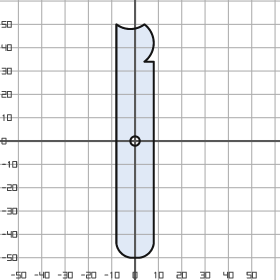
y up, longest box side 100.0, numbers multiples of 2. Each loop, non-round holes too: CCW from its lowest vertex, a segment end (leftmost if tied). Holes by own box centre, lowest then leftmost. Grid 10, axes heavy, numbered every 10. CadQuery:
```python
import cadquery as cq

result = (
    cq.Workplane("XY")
    .moveTo(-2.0, -50.0)
    .lineTo(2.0, -50.0)
    .threePointArc((6.0, -48.0), (8.0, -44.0))
    .lineTo(8.0, 34.0)
    .lineTo(4.0, 34.0)
    .threePointArc((8.0, 42.0), (4.0, 50.0))
    .threePointArc((-2.0, 48.0), (-8.0, 50.0))
    .lineTo(-8.0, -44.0)
    .threePointArc((-6.0, -48.0), (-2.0, -50.0))
    .close()
    .moveTo(0.0, 0.0)
    .circle(2.0)
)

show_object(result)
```